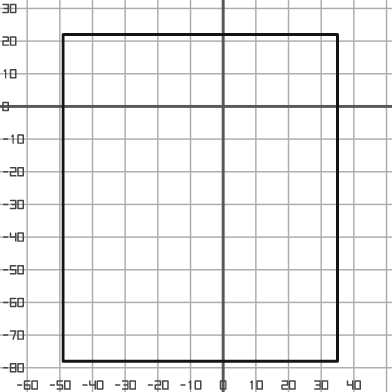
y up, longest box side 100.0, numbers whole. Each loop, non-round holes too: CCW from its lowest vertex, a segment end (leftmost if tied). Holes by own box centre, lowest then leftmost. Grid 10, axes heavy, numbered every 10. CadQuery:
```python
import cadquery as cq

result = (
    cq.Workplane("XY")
    .moveTo(-49.0, -78.0)
    .lineTo(35.0, -78.0)
    .lineTo(35.0, 22.0)
    .lineTo(-49.0, 22.0)
    .close()
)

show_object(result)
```